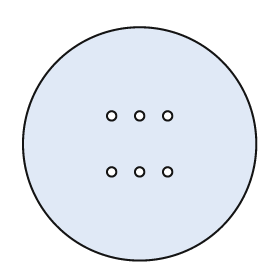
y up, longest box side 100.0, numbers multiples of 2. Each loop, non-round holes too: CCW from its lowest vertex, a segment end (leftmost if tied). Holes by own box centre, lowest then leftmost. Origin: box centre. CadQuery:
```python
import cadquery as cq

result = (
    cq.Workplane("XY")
    .moveTo(0.0, 0.0)
    .circle(50.0)
    .moveTo(-12.0, -12.0)
    .circle(2.0)
    .moveTo(0.0, -12.0)
    .circle(2.0)
    .moveTo(12.0, -12.0)
    .circle(2.0)
    .moveTo(-12.0, 12.0)
    .circle(2.0)
    .moveTo(0.0, 12.0)
    .circle(2.0)
    .moveTo(12.0, 12.0)
    .circle(2.0)
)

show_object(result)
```